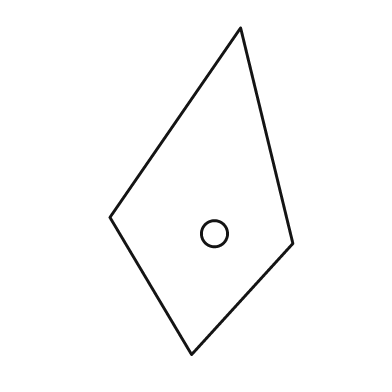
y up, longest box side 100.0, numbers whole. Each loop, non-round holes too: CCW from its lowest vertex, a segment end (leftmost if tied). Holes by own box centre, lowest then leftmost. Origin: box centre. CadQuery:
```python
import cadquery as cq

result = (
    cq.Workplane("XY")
    .moveTo(-3.0, -50.0)
    .lineTo(28.0, -16.0)
    .lineTo(12.0, 50.0)
    .lineTo(-28.0, -8.0)
    .close()
    .moveTo(4.0, -13.0)
    .circle(4.0)
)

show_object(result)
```